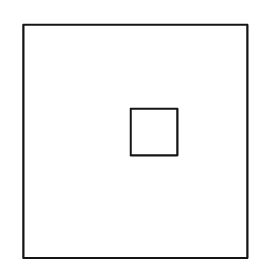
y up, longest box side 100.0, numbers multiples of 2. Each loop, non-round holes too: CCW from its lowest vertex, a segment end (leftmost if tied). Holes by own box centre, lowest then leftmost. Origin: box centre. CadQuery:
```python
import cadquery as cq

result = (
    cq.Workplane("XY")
    .moveTo(-48.0, -50.0)
    .lineTo(48.0, -50.0)
    .lineTo(48.0, 50.0)
    .lineTo(-48.0, 50.0)
    .close()
    .moveTo(-2.0, -6.0)
    .lineTo(18.0, -6.0)
    .lineTo(18.0, 14.0)
    .lineTo(-2.0, 14.0)
    .close()
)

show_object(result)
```